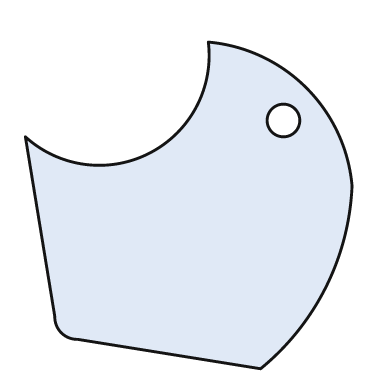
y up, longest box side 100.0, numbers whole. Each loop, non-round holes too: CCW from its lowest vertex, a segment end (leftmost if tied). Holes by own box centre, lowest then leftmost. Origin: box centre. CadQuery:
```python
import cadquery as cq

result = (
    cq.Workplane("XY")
    .moveTo(22.0, -50.0)
    .threePointArc((42.0, -25.0), (50.0, 6.0))
    .threePointArc((36.0, 36.0), (6.0, 50.0))
    .threePointArc((-12.0, 16.0), (-50.0, 21.0))
    .lineTo(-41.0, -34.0)
    .threePointArc((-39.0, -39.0), (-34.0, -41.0))
    .close()
    .moveTo(29.0, 26.0)
    .circle(5.0)
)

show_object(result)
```